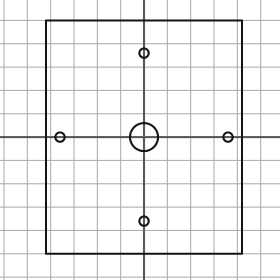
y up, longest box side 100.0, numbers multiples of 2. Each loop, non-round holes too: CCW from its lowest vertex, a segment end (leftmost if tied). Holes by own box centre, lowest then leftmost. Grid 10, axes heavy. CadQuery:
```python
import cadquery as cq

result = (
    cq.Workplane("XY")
    .moveTo(-42.0, -50.0)
    .lineTo(42.0, -50.0)
    .lineTo(42.0, 50.0)
    .lineTo(-42.0, 50.0)
    .close()
    .moveTo(0.0, -36.0)
    .circle(2.0)
    .moveTo(-36.0, 0.0)
    .circle(2.0)
    .moveTo(0.0, 0.0)
    .circle(6.0)
    .moveTo(36.0, 0.0)
    .circle(2.0)
    .moveTo(0.0, 36.0)
    .circle(2.0)
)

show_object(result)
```